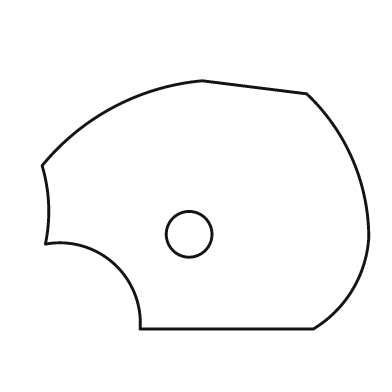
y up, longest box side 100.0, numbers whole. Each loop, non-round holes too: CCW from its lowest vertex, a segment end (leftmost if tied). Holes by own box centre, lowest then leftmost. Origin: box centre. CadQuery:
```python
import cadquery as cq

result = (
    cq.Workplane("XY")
    .moveTo(-20.0, -38.0)
    .lineTo(33.0, -38.0)
    .threePointArc((45.0, -26.0), (50.0, -10.0))
    .threePointArc((45.0, 14.0), (31.0, 34.0))
    .lineTo(-1.0, 38.0)
    .threePointArc((-28.0, 30.0), (-50.0, 12.0))
    .threePointArc((-48.0, 0.0), (-49.0, -12.0))
    .threePointArc((-28.0, -18.0), (-20.0, -38.0))
    .close()
    .moveTo(-5.0, -9.0)
    .circle(7.0)
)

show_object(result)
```